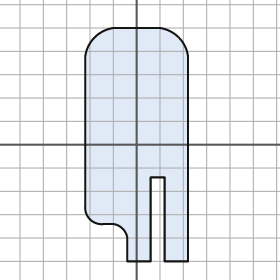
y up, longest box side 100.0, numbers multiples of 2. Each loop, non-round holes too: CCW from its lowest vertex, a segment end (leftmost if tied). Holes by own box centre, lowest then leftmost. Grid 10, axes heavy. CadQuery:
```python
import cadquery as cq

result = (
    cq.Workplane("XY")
    .moveTo(-4.0, -50.0)
    .lineTo(6.0, -50.0)
    .lineTo(6.0, -14.0)
    .lineTo(12.0, -14.0)
    .lineTo(12.0, -50.0)
    .lineTo(22.0, -50.0)
    .lineTo(22.0, 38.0)
    .threePointArc((18.0, 46.0), (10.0, 50.0))
    .lineTo(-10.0, 50.0)
    .threePointArc((-18.0, 46.0), (-22.0, 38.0))
    .lineTo(-22.0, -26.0)
    .threePointArc((-20.0, -32.0), (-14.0, -34.0))
    .lineTo(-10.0, -34.0)
    .threePointArc((-6.0, -36.0), (-4.0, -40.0))
    .close()
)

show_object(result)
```